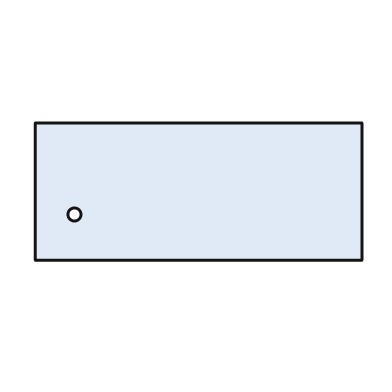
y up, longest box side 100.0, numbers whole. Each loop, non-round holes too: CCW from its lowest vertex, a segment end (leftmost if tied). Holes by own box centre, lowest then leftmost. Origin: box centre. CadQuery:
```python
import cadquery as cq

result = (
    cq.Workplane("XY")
    .moveTo(-50.0, -21.0)
    .lineTo(50.0, -21.0)
    .lineTo(50.0, 21.0)
    .lineTo(-50.0, 21.0)
    .close()
    .moveTo(-38.0, -7.0)
    .circle(2.0)
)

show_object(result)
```